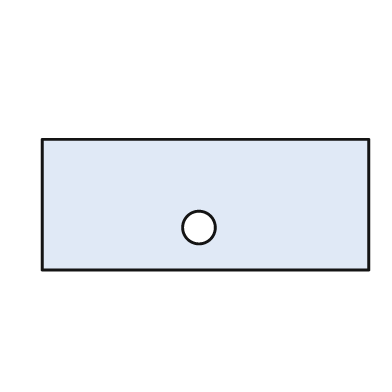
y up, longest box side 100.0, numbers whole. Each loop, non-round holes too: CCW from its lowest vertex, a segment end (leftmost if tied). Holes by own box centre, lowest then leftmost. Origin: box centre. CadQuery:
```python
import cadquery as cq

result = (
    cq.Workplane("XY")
    .moveTo(-50.0, -20.0)
    .lineTo(50.0, -20.0)
    .lineTo(50.0, 20.0)
    .lineTo(-50.0, 20.0)
    .close()
    .moveTo(-2.0, -7.0)
    .circle(5.0)
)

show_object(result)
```